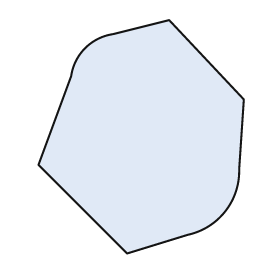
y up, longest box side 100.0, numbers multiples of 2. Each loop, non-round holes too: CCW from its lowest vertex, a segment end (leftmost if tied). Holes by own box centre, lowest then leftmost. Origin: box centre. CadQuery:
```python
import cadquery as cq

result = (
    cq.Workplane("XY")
    .moveTo(-6.0, -50.0)
    .lineTo(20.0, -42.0)
    .threePointArc((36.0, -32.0), (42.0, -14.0))
    .lineTo(44.0, 16.0)
    .lineTo(12.0, 50.0)
    .lineTo(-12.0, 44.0)
    .threePointArc((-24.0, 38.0), (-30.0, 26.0))
    .lineTo(-44.0, -12.0)
    .close()
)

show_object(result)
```